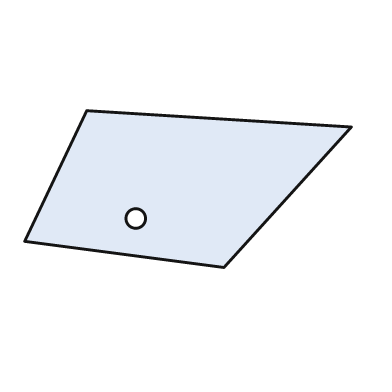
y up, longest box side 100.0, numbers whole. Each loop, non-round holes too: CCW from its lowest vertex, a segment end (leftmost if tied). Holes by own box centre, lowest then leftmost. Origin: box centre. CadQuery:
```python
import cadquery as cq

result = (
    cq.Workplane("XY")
    .moveTo(11.0, -24.0)
    .lineTo(50.0, 19.0)
    .lineTo(-31.0, 24.0)
    .lineTo(-50.0, -16.0)
    .close()
    .moveTo(-16.0, -9.0)
    .circle(3.0)
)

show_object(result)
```